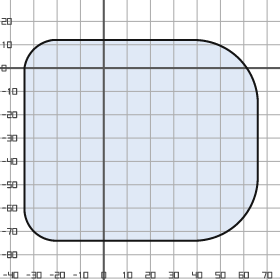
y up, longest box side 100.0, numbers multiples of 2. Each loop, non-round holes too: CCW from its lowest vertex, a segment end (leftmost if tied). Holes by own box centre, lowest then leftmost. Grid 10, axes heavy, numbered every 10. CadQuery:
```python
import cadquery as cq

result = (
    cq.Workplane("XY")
    .moveTo(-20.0, -74.0)
    .lineTo(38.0, -74.0)
    .threePointArc((58.0, -66.0), (66.0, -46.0))
    .lineTo(66.0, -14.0)
    .threePointArc((58.0, 4.0), (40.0, 12.0))
    .lineTo(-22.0, 12.0)
    .threePointArc((-30.0, 8.0), (-34.0, 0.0))
    .lineTo(-34.0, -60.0)
    .threePointArc((-30.0, -70.0), (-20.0, -74.0))
    .close()
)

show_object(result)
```